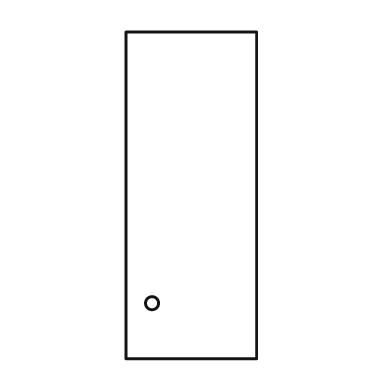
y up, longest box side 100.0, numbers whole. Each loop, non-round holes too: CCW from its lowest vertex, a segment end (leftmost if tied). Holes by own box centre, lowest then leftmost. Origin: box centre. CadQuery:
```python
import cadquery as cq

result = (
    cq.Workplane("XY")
    .moveTo(-20.0, -50.0)
    .lineTo(20.0, -50.0)
    .lineTo(20.0, 50.0)
    .lineTo(-20.0, 50.0)
    .close()
    .moveTo(-12.0, -33.0)
    .circle(2.0)
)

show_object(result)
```